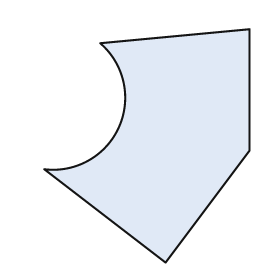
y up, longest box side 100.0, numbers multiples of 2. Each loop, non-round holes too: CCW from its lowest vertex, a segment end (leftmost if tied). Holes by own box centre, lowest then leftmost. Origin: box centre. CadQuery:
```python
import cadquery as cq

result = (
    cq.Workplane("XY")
    .moveTo(8.0, -50.0)
    .lineTo(44.0, -2.0)
    .lineTo(44.0, 50.0)
    .lineTo(-20.0, 44.0)
    .threePointArc((-12.0, 8.0), (-44.0, -10.0))
    .close()
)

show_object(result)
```